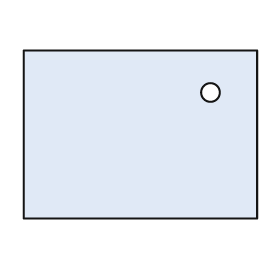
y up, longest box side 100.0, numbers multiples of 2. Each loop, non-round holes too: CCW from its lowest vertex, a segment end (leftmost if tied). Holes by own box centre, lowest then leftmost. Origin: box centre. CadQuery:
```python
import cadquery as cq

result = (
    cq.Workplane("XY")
    .moveTo(-50.0, -36.0)
    .lineTo(50.0, -36.0)
    .lineTo(50.0, 36.0)
    .lineTo(-50.0, 36.0)
    .close()
    .moveTo(30.0, 18.0)
    .circle(4.0)
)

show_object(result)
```